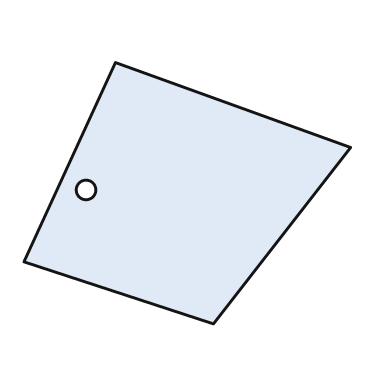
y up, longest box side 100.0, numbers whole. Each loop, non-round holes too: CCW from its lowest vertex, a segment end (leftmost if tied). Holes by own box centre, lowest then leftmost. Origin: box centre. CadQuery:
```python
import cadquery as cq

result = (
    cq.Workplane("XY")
    .moveTo(8.0, -40.0)
    .lineTo(50.0, 14.0)
    .lineTo(-22.0, 40.0)
    .lineTo(-50.0, -21.0)
    .close()
    .moveTo(-31.0, 1.0)
    .circle(3.0)
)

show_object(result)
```